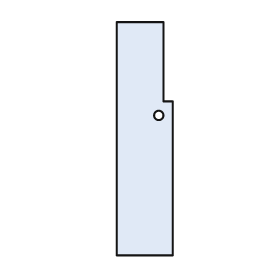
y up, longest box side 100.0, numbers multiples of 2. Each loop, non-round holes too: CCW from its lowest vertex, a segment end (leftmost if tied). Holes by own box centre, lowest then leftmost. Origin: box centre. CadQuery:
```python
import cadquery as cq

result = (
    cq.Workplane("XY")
    .moveTo(-12.0, -50.0)
    .lineTo(12.0, -50.0)
    .lineTo(12.0, 16.0)
    .lineTo(8.0, 16.0)
    .lineTo(8.0, 50.0)
    .lineTo(-12.0, 50.0)
    .close()
    .moveTo(6.0, 10.0)
    .circle(2.0)
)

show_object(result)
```